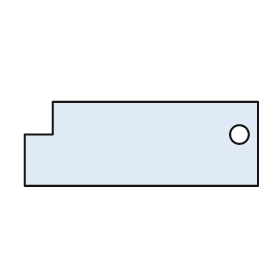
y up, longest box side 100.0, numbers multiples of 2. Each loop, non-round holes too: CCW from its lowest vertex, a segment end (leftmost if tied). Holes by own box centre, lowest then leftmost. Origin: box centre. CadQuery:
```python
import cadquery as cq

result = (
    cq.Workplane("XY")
    .moveTo(-50.0, -18.0)
    .lineTo(50.0, -18.0)
    .lineTo(50.0, 18.0)
    .lineTo(-38.0, 18.0)
    .lineTo(-38.0, 4.0)
    .lineTo(-50.0, 4.0)
    .close()
    .moveTo(42.0, 4.0)
    .circle(4.0)
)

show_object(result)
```